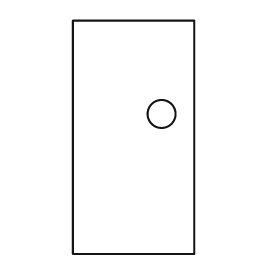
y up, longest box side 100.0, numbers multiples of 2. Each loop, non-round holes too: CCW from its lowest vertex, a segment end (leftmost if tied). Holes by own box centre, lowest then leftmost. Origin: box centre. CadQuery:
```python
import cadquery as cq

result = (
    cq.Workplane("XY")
    .moveTo(-26.0, -50.0)
    .lineTo(26.0, -50.0)
    .lineTo(26.0, 50.0)
    .lineTo(-26.0, 50.0)
    .close()
    .moveTo(12.0, 10.0)
    .circle(6.0)
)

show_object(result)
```